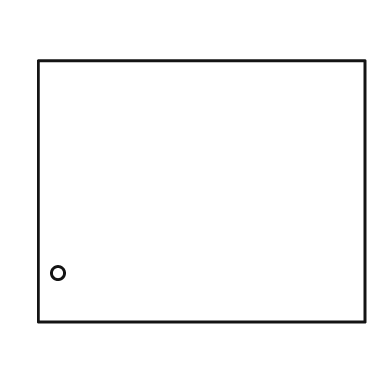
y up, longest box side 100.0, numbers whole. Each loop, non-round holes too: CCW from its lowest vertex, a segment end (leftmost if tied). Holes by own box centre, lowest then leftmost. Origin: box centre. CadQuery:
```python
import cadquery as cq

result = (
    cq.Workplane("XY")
    .moveTo(-50.0, -40.0)
    .lineTo(50.0, -40.0)
    .lineTo(50.0, 40.0)
    .lineTo(-50.0, 40.0)
    .close()
    .moveTo(-44.0, -25.0)
    .circle(2.0)
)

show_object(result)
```